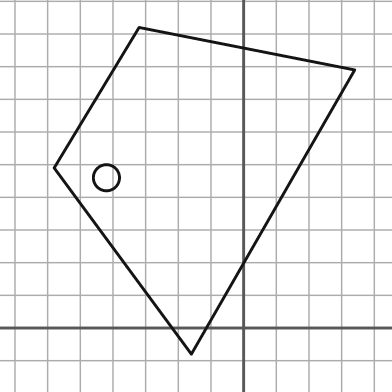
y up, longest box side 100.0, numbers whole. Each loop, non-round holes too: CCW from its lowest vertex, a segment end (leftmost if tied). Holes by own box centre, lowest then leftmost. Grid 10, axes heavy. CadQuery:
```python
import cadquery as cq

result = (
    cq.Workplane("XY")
    .moveTo(-16.0, -8.0)
    .lineTo(34.0, 79.0)
    .lineTo(-32.0, 92.0)
    .lineTo(-58.0, 49.0)
    .close()
    .moveTo(-42.0, 46.0)
    .circle(4.0)
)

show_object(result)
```